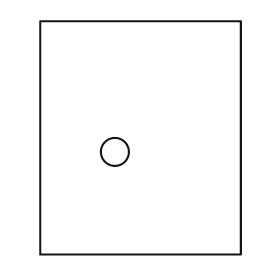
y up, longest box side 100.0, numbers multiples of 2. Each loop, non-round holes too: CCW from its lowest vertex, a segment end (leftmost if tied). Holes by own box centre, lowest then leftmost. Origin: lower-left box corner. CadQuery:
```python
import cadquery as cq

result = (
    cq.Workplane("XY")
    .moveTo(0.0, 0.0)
    .lineTo(86.0, 0.0)
    .lineTo(86.0, 100.0)
    .lineTo(0.0, 100.0)
    .close()
    .moveTo(32.0, 44.0)
    .circle(6.0)
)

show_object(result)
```